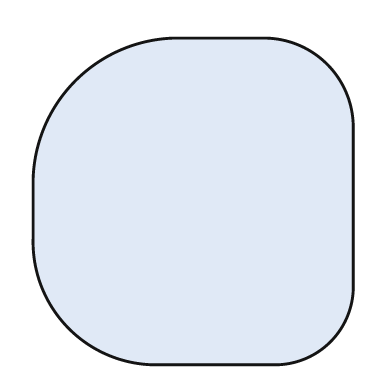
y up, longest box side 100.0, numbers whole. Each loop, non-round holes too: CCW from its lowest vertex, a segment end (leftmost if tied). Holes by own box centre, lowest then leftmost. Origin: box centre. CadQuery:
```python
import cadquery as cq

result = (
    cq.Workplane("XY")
    .moveTo(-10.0, -50.0)
    .lineTo(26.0, -50.0)
    .threePointArc((42.0, -43.0), (49.0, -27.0))
    .lineTo(49.0, 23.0)
    .threePointArc((41.0, 42.0), (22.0, 50.0))
    .lineTo(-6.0, 50.0)
    .threePointArc((-36.0, 37.0), (-49.0, 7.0))
    .lineTo(-49.0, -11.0)
    .threePointArc((-38.0, -39.0), (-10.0, -50.0))
    .close()
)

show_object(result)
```